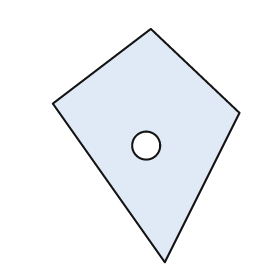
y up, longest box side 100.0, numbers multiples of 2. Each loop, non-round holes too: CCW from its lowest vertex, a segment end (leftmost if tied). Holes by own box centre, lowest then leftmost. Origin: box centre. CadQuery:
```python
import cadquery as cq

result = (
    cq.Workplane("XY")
    .moveTo(8.0, -50.0)
    .lineTo(40.0, 14.0)
    .lineTo(2.0, 50.0)
    .lineTo(-40.0, 18.0)
    .close()
    .moveTo(0.0, 0.0)
    .circle(6.0)
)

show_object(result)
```